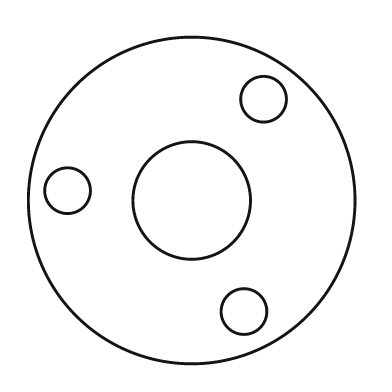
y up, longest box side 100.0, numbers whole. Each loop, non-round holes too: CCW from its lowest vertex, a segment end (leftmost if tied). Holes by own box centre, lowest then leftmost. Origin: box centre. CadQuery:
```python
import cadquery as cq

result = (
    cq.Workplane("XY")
    .moveTo(0.0, 0.0)
    .circle(50.0)
    .moveTo(16.0, -34.0)
    .circle(7.0)
    .moveTo(0.0, 0.0)
    .circle(18.0)
    .moveTo(-38.0, 3.0)
    .circle(7.0)
    .moveTo(22.0, 31.0)
    .circle(7.0)
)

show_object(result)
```